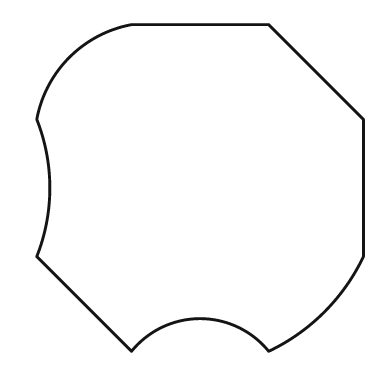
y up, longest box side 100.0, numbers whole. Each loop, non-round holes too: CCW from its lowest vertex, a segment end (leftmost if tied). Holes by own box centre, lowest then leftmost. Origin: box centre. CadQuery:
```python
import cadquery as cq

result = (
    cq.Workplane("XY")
    .moveTo(-21.0, -50.0)
    .threePointArc((0.0, -40.0), (21.0, -50.0))
    .threePointArc((38.0, -38.0), (50.0, -21.0))
    .lineTo(50.0, 21.0)
    .lineTo(21.0, 50.0)
    .lineTo(-21.0, 50.0)
    .threePointArc((-40.0, 40.0), (-50.0, 21.0))
    .threePointArc((-46.0, 0.0), (-50.0, -21.0))
    .close()
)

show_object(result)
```